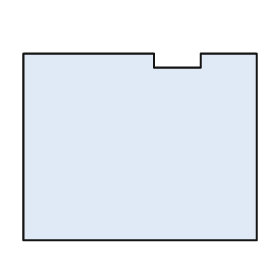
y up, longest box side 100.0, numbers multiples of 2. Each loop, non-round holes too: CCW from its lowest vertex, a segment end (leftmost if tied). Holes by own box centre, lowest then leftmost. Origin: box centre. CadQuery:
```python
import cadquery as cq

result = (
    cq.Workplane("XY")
    .moveTo(-50.0, -40.0)
    .lineTo(50.0, -40.0)
    .lineTo(50.0, 40.0)
    .lineTo(26.0, 40.0)
    .lineTo(26.0, 34.0)
    .lineTo(6.0, 34.0)
    .lineTo(6.0, 40.0)
    .lineTo(-50.0, 40.0)
    .close()
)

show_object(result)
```